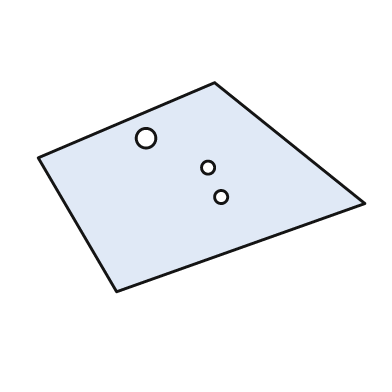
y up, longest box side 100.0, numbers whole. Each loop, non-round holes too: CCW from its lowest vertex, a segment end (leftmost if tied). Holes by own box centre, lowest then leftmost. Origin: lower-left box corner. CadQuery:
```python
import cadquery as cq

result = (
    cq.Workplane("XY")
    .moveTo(24.0, 0.0)
    .lineTo(100.0, 27.0)
    .lineTo(54.0, 64.0)
    .lineTo(0.0, 41.0)
    .close()
    .moveTo(56.0, 29.0)
    .circle(2.0)
    .moveTo(52.0, 38.0)
    .circle(2.0)
    .moveTo(33.0, 47.0)
    .circle(3.0)
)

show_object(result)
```